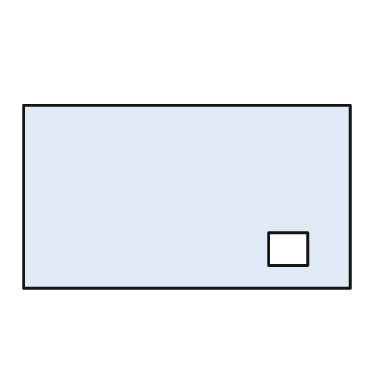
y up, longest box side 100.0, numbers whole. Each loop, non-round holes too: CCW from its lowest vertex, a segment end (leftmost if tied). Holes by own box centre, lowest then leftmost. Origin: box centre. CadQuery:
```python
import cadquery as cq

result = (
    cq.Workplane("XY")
    .moveTo(-50.0, -28.0)
    .lineTo(50.0, -28.0)
    .lineTo(50.0, 28.0)
    .lineTo(-50.0, 28.0)
    .close()
    .moveTo(25.0, -21.0)
    .lineTo(37.0, -21.0)
    .lineTo(37.0, -11.0)
    .lineTo(25.0, -11.0)
    .close()
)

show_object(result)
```